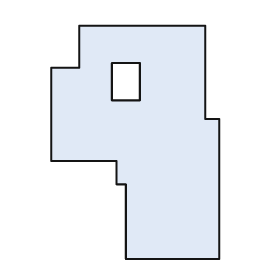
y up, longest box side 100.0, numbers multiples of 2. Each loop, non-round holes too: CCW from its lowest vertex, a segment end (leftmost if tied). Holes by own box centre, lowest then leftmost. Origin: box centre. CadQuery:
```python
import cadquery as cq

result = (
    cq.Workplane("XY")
    .moveTo(-4.0, -50.0)
    .lineTo(36.0, -50.0)
    .lineTo(36.0, 10.0)
    .lineTo(30.0, 10.0)
    .lineTo(30.0, 50.0)
    .lineTo(-24.0, 50.0)
    .lineTo(-24.0, 32.0)
    .lineTo(-36.0, 32.0)
    .lineTo(-36.0, -8.0)
    .lineTo(-8.0, -8.0)
    .lineTo(-8.0, -18.0)
    .lineTo(-4.0, -18.0)
    .close()
    .moveTo(-10.0, 18.0)
    .lineTo(2.0, 18.0)
    .lineTo(2.0, 34.0)
    .lineTo(-10.0, 34.0)
    .close()
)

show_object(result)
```